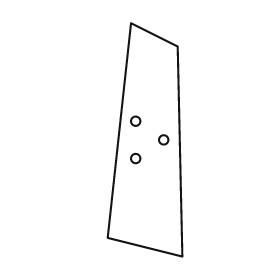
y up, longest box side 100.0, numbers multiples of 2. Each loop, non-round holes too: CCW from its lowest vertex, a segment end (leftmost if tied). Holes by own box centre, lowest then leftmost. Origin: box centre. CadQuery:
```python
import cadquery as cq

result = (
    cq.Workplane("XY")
    .moveTo(16.0, -50.0)
    .lineTo(14.0, 40.0)
    .lineTo(-6.0, 50.0)
    .lineTo(-16.0, -42.0)
    .close()
    .moveTo(-4.0, -8.0)
    .circle(2.0)
    .moveTo(8.0, 0.0)
    .circle(2.0)
    .moveTo(-4.0, 8.0)
    .circle(2.0)
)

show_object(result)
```